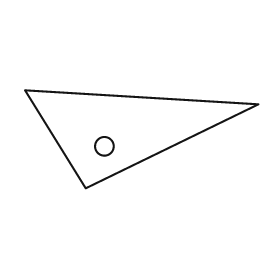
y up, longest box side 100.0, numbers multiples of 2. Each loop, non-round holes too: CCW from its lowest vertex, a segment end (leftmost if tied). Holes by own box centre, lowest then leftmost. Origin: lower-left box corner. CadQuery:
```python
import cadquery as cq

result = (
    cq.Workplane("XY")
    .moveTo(26.0, 0.0)
    .lineTo(100.0, 36.0)
    .lineTo(0.0, 42.0)
    .close()
    .moveTo(34.0, 18.0)
    .circle(4.0)
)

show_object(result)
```